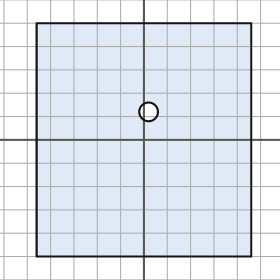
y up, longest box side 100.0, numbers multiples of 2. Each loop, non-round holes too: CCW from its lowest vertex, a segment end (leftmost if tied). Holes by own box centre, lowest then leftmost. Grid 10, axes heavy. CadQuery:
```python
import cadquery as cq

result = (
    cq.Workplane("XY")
    .moveTo(-46.0, -50.0)
    .lineTo(46.0, -50.0)
    .lineTo(46.0, 50.0)
    .lineTo(-46.0, 50.0)
    .close()
    .moveTo(2.0, 12.0)
    .circle(4.0)
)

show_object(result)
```